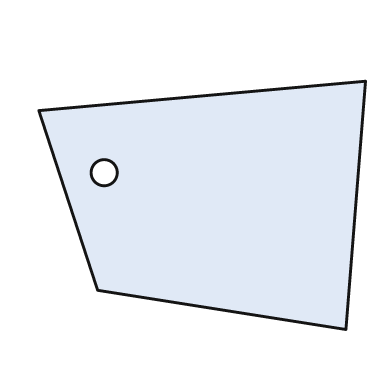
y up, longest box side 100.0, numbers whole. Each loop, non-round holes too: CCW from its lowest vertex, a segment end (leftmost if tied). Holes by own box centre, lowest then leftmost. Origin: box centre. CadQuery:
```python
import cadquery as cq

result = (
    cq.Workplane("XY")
    .moveTo(44.0, -38.0)
    .lineTo(50.0, 38.0)
    .lineTo(-50.0, 29.0)
    .lineTo(-32.0, -26.0)
    .close()
    .moveTo(-30.0, 10.0)
    .circle(4.0)
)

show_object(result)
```